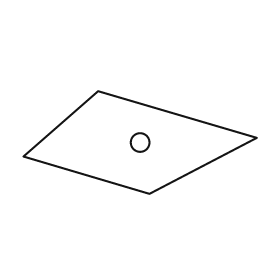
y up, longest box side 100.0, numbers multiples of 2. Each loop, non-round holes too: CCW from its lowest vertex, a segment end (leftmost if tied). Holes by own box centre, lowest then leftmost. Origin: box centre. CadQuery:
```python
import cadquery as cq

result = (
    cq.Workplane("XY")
    .moveTo(4.0, -22.0)
    .lineTo(50.0, 2.0)
    .lineTo(-18.0, 22.0)
    .lineTo(-50.0, -6.0)
    .close()
    .moveTo(0.0, 0.0)
    .circle(4.0)
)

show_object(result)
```